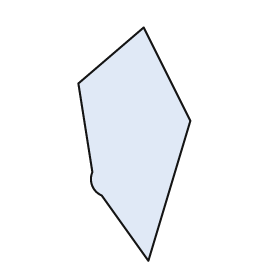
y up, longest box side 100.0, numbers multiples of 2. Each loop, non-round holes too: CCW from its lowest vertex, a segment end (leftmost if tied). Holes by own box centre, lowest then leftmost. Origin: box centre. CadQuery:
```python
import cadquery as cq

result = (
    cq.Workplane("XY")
    .moveTo(6.0, -50.0)
    .lineTo(24.0, 10.0)
    .lineTo(4.0, 50.0)
    .lineTo(-24.0, 26.0)
    .lineTo(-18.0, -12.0)
    .threePointArc((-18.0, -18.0), (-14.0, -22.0))
    .close()
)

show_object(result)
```